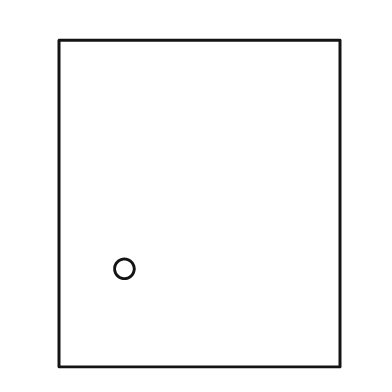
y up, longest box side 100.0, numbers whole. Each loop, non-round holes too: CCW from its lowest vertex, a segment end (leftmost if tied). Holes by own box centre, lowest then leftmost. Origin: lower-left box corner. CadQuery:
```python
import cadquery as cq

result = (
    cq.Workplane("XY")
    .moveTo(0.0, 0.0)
    .lineTo(86.0, 0.0)
    .lineTo(86.0, 100.0)
    .lineTo(0.0, 100.0)
    .close()
    .moveTo(20.0, 30.0)
    .circle(3.0)
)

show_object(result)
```